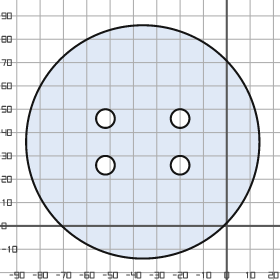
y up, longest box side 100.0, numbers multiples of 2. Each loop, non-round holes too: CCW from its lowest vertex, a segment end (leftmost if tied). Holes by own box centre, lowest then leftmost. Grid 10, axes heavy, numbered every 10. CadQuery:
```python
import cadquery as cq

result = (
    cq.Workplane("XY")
    .moveTo(-36.0, 36.0)
    .circle(50.0)
    .moveTo(-52.0, 26.0)
    .circle(4.0)
    .moveTo(-20.0, 26.0)
    .circle(4.0)
    .moveTo(-52.0, 46.0)
    .circle(4.0)
    .moveTo(-20.0, 46.0)
    .circle(4.0)
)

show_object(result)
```